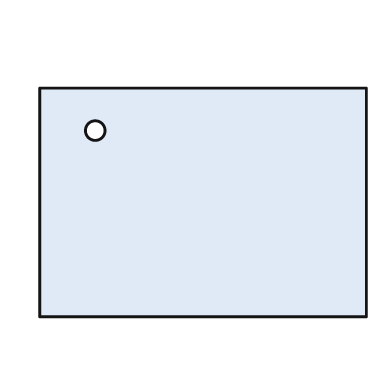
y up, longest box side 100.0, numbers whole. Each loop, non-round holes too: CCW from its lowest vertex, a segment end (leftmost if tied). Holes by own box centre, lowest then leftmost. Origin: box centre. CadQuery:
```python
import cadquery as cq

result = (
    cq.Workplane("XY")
    .moveTo(-50.0, -35.0)
    .lineTo(50.0, -35.0)
    .lineTo(50.0, 35.0)
    .lineTo(-50.0, 35.0)
    .close()
    .moveTo(-33.0, 22.0)
    .circle(3.0)
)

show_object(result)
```